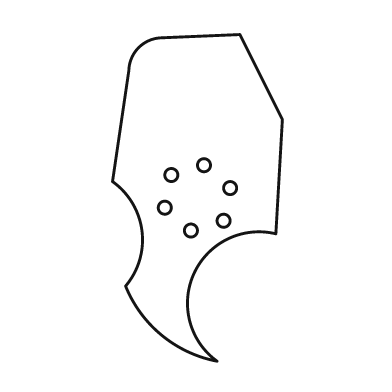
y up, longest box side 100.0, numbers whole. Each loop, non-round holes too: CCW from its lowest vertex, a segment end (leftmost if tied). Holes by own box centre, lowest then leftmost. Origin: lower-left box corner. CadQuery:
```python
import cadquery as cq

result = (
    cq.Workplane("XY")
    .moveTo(32.0, 0.0)
    .threePointArc((25.0, 27.0), (50.0, 39.0))
    .lineTo(52.0, 74.0)
    .lineTo(39.0, 100.0)
    .lineTo(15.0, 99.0)
    .threePointArc((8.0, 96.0), (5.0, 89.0))
    .lineTo(0.0, 55.0)
    .threePointArc((9.0, 40.0), (4.0, 23.0))
    .threePointArc((15.0, 8.0), (32.0, 0.0))
    .close()
    .moveTo(24.0, 40.0)
    .circle(2.0)
    .moveTo(34.0, 43.0)
    .circle(2.0)
    .moveTo(16.0, 47.0)
    .circle(2.0)
    .moveTo(36.0, 53.0)
    .circle(2.0)
    .moveTo(18.0, 57.0)
    .circle(2.0)
    .moveTo(28.0, 60.0)
    .circle(2.0)
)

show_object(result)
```